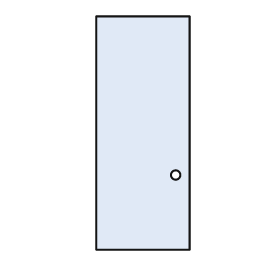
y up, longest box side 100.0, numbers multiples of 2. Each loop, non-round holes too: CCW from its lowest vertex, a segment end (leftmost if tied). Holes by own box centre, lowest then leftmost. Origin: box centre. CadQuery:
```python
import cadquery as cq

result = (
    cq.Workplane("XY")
    .moveTo(-20.0, -50.0)
    .lineTo(20.0, -50.0)
    .lineTo(20.0, 50.0)
    .lineTo(-20.0, 50.0)
    .close()
    .moveTo(14.0, -18.0)
    .circle(2.0)
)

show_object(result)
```